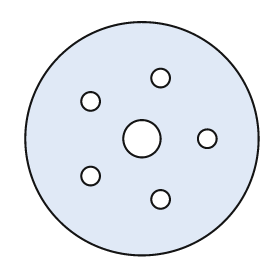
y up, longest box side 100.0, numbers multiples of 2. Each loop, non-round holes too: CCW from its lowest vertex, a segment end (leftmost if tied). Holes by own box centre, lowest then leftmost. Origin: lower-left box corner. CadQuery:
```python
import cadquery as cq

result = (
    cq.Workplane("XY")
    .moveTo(50.0, 50.0)
    .circle(50.0)
    .moveTo(58.0, 24.0)
    .circle(4.0)
    .moveTo(28.0, 34.0)
    .circle(4.0)
    .moveTo(50.0, 50.0)
    .circle(8.0)
    .moveTo(78.0, 50.0)
    .circle(4.0)
    .moveTo(28.0, 66.0)
    .circle(4.0)
    .moveTo(58.0, 76.0)
    .circle(4.0)
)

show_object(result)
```